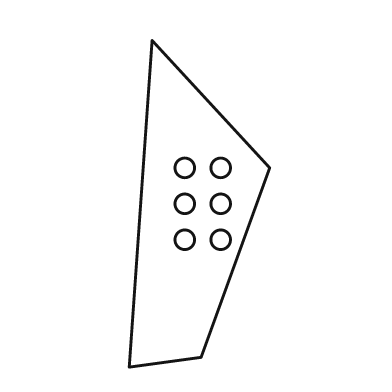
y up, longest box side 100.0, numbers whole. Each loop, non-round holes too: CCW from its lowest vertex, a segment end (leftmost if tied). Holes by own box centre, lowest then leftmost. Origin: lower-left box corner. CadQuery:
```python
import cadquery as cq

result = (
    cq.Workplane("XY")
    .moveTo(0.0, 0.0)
    .lineTo(22.0, 3.0)
    .lineTo(43.0, 61.0)
    .lineTo(7.0, 100.0)
    .close()
    .moveTo(17.0, 39.0)
    .circle(3.0)
    .moveTo(28.0, 39.0)
    .circle(3.0)
    .moveTo(17.0, 50.0)
    .circle(3.0)
    .moveTo(28.0, 50.0)
    .circle(3.0)
    .moveTo(17.0, 61.0)
    .circle(3.0)
    .moveTo(28.0, 61.0)
    .circle(3.0)
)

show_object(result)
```